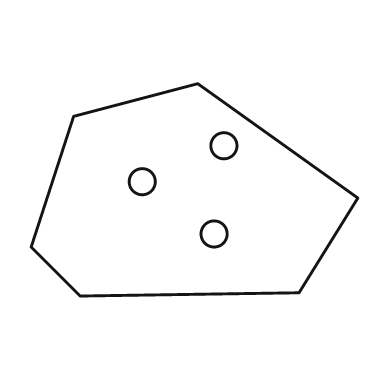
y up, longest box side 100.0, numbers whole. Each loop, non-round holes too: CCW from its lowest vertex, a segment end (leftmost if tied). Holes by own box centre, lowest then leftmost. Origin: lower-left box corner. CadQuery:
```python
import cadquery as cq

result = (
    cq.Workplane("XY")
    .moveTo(15.0, 0.0)
    .lineTo(82.0, 1.0)
    .lineTo(100.0, 30.0)
    .lineTo(51.0, 65.0)
    .lineTo(13.0, 55.0)
    .lineTo(0.0, 15.0)
    .close()
    .moveTo(56.0, 19.0)
    .circle(4.0)
    .moveTo(34.0, 35.0)
    .circle(4.0)
    .moveTo(59.0, 46.0)
    .circle(4.0)
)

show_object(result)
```